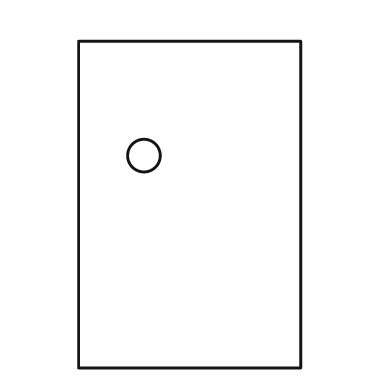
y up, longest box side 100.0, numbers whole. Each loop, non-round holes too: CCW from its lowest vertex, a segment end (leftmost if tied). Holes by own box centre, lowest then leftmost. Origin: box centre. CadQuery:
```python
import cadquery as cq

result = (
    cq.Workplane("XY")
    .moveTo(-34.0, -50.0)
    .lineTo(34.0, -50.0)
    .lineTo(34.0, 50.0)
    .lineTo(-34.0, 50.0)
    .close()
    .moveTo(-14.0, 15.0)
    .circle(5.0)
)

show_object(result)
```